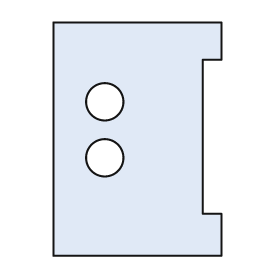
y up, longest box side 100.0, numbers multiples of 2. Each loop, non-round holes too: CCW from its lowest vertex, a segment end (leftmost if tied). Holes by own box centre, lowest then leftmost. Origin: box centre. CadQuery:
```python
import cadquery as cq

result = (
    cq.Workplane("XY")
    .moveTo(-36.0, -50.0)
    .lineTo(36.0, -50.0)
    .lineTo(36.0, -32.0)
    .lineTo(28.0, -32.0)
    .lineTo(28.0, 34.0)
    .lineTo(36.0, 34.0)
    .lineTo(36.0, 50.0)
    .lineTo(-36.0, 50.0)
    .close()
    .moveTo(-14.0, -8.0)
    .circle(8.0)
    .moveTo(-14.0, 16.0)
    .circle(8.0)
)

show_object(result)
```